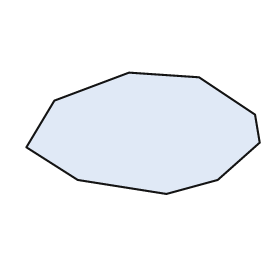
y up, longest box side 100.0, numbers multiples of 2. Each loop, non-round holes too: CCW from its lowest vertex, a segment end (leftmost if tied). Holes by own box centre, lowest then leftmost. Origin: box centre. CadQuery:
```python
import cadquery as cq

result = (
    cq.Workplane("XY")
    .moveTo(10.0, -26.0)
    .lineTo(32.0, -20.0)
    .lineTo(50.0, -4.0)
    .lineTo(48.0, 8.0)
    .lineTo(24.0, 24.0)
    .lineTo(-6.0, 26.0)
    .lineTo(-38.0, 14.0)
    .lineTo(-50.0, -6.0)
    .lineTo(-28.0, -20.0)
    .close()
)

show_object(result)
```